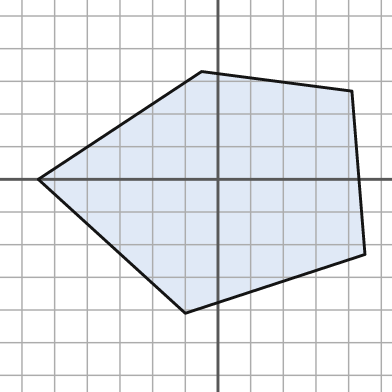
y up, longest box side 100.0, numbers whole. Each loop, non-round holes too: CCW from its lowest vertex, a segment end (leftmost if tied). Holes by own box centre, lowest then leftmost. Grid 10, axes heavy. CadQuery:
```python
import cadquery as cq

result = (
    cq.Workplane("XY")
    .moveTo(-10.0, -41.0)
    .lineTo(45.0, -23.0)
    .lineTo(41.0, 27.0)
    .lineTo(-5.0, 33.0)
    .lineTo(-55.0, 0.0)
    .close()
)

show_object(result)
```